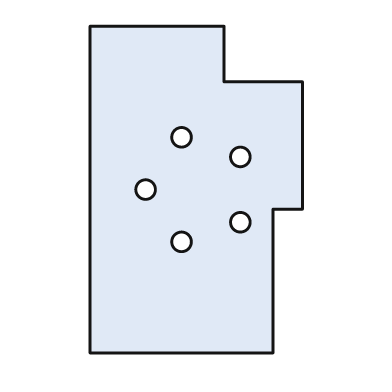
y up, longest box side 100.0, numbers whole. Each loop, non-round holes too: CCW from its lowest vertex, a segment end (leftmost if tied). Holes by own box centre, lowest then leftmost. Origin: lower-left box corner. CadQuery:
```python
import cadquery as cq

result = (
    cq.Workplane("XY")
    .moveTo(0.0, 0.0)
    .lineTo(56.0, 0.0)
    .lineTo(56.0, 44.0)
    .lineTo(65.0, 44.0)
    .lineTo(65.0, 83.0)
    .lineTo(41.0, 83.0)
    .lineTo(41.0, 100.0)
    .lineTo(0.0, 100.0)
    .close()
    .moveTo(28.0, 34.0)
    .circle(3.0)
    .moveTo(46.0, 40.0)
    .circle(3.0)
    .moveTo(17.0, 50.0)
    .circle(3.0)
    .moveTo(46.0, 60.0)
    .circle(3.0)
    .moveTo(28.0, 66.0)
    .circle(3.0)
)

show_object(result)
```